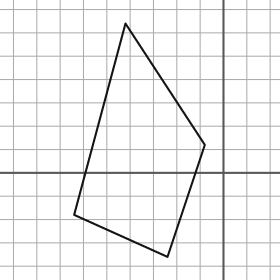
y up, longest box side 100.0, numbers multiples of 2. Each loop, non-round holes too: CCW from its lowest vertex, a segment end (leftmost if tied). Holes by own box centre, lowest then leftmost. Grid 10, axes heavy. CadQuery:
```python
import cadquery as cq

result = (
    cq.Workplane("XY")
    .moveTo(-24.0, -36.0)
    .lineTo(-8.0, 12.0)
    .lineTo(-42.0, 64.0)
    .lineTo(-64.0, -18.0)
    .close()
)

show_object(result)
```